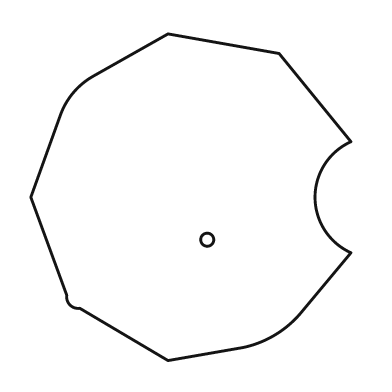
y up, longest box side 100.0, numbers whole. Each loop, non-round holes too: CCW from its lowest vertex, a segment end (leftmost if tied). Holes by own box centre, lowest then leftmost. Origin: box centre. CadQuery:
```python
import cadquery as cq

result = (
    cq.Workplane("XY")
    .moveTo(-7.0, -50.0)
    .lineTo(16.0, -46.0)
    .threePointArc((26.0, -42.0), (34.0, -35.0))
    .lineTo(49.0, -17.0)
    .threePointArc((38.0, 0.0), (49.0, 17.0))
    .lineTo(27.0, 44.0)
    .lineTo(-7.0, 50.0)
    .lineTo(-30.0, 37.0)
    .threePointArc((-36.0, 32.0), (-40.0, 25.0))
    .lineTo(-49.0, 0.0)
    .lineTo(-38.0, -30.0)
    .threePointArc((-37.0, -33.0), (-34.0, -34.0))
    .close()
    .moveTo(5.0, -13.0)
    .circle(2.0)
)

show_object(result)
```